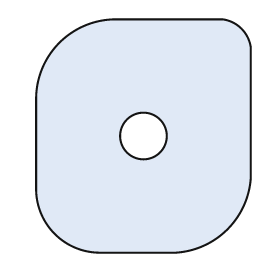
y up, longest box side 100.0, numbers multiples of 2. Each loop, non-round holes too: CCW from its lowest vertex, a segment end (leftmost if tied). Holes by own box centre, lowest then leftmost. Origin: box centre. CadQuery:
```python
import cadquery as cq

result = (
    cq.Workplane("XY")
    .moveTo(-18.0, -50.0)
    .lineTo(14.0, -50.0)
    .threePointArc((36.0, -40.0), (46.0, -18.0))
    .lineTo(46.0, 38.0)
    .threePointArc((42.0, 46.0), (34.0, 50.0))
    .lineTo(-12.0, 50.0)
    .threePointArc((-36.0, 40.0), (-46.0, 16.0))
    .lineTo(-46.0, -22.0)
    .threePointArc((-38.0, -42.0), (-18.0, -50.0))
    .close()
    .moveTo(0.0, 0.0)
    .circle(10.0)
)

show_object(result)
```